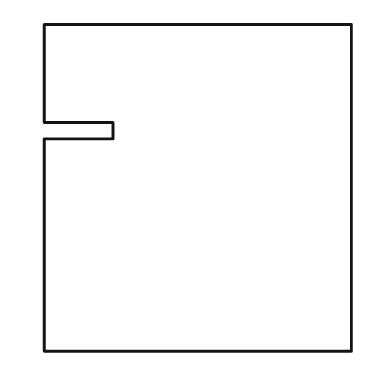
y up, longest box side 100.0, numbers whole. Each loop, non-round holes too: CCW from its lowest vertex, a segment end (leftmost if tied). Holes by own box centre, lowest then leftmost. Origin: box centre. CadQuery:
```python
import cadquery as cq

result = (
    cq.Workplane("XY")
    .moveTo(-47.0, -50.0)
    .lineTo(47.0, -50.0)
    .lineTo(47.0, 50.0)
    .lineTo(-47.0, 50.0)
    .lineTo(-47.0, 20.0)
    .lineTo(-26.0, 20.0)
    .lineTo(-26.0, 15.0)
    .lineTo(-47.0, 15.0)
    .close()
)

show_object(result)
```